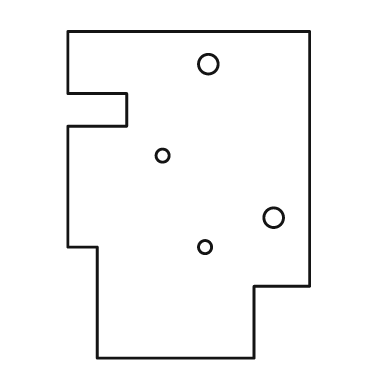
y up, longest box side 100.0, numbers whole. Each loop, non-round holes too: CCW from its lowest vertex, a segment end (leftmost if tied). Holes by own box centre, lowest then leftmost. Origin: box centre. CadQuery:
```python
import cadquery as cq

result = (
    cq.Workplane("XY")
    .moveTo(-28.0, -50.0)
    .lineTo(20.0, -50.0)
    .lineTo(20.0, -28.0)
    .lineTo(37.0, -28.0)
    .lineTo(37.0, 50.0)
    .lineTo(-37.0, 50.0)
    .lineTo(-37.0, 31.0)
    .lineTo(-19.0, 31.0)
    .lineTo(-19.0, 21.0)
    .lineTo(-37.0, 21.0)
    .lineTo(-37.0, -16.0)
    .lineTo(-28.0, -16.0)
    .close()
    .moveTo(5.0, -16.0)
    .circle(2.0)
    .moveTo(26.0, -7.0)
    .circle(3.0)
    .moveTo(-8.0, 12.0)
    .circle(2.0)
    .moveTo(6.0, 40.0)
    .circle(3.0)
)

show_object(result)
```